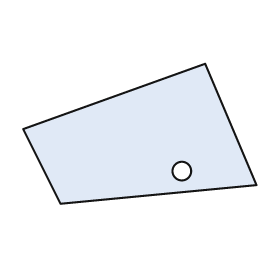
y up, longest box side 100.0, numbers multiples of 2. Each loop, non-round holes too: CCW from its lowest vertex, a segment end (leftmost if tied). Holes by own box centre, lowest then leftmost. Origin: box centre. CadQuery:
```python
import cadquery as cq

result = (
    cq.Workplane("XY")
    .moveTo(-34.0, -30.0)
    .lineTo(50.0, -22.0)
    .lineTo(28.0, 30.0)
    .lineTo(-50.0, 2.0)
    .close()
    .moveTo(18.0, -16.0)
    .circle(4.0)
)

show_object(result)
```